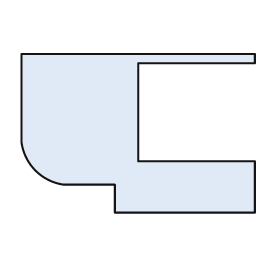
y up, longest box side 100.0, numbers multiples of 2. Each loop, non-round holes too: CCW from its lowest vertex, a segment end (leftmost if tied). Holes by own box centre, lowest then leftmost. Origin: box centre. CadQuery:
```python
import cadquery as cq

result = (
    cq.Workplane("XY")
    .moveTo(-10.0, -34.0)
    .lineTo(50.0, -34.0)
    .lineTo(50.0, -12.0)
    .lineTo(0.0, -12.0)
    .lineTo(0.0, 30.0)
    .lineTo(50.0, 30.0)
    .lineTo(50.0, 34.0)
    .lineTo(-50.0, 34.0)
    .lineTo(-50.0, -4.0)
    .threePointArc((-44.0, -16.0), (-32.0, -22.0))
    .lineTo(-10.0, -22.0)
    .close()
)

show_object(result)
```